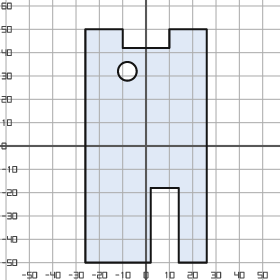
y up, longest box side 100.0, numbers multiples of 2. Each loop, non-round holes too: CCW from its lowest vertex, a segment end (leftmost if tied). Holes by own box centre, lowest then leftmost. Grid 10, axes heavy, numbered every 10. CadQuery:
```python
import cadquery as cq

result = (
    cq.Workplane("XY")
    .moveTo(-26.0, -50.0)
    .lineTo(2.0, -50.0)
    .lineTo(2.0, -18.0)
    .lineTo(14.0, -18.0)
    .lineTo(14.0, -50.0)
    .lineTo(26.0, -50.0)
    .lineTo(26.0, 50.0)
    .lineTo(10.0, 50.0)
    .lineTo(10.0, 42.0)
    .lineTo(-10.0, 42.0)
    .lineTo(-10.0, 50.0)
    .lineTo(-26.0, 50.0)
    .close()
    .moveTo(-8.0, 32.0)
    .circle(4.0)
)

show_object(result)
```